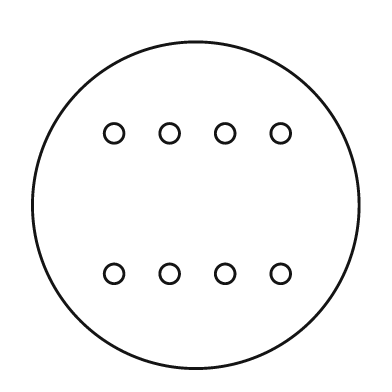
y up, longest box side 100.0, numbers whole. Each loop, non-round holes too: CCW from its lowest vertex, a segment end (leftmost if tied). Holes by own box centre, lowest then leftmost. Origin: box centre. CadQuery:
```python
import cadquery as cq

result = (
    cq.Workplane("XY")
    .moveTo(0.0, 0.0)
    .circle(50.0)
    .moveTo(-25.0, -21.0)
    .circle(3.0)
    .moveTo(-8.0, -21.0)
    .circle(3.0)
    .moveTo(9.0, -21.0)
    .circle(3.0)
    .moveTo(26.0, -21.0)
    .circle(3.0)
    .moveTo(-25.0, 22.0)
    .circle(3.0)
    .moveTo(-8.0, 22.0)
    .circle(3.0)
    .moveTo(9.0, 22.0)
    .circle(3.0)
    .moveTo(26.0, 22.0)
    .circle(3.0)
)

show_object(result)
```